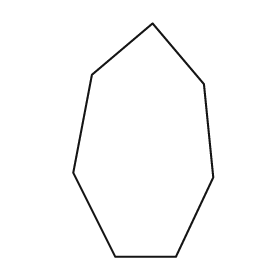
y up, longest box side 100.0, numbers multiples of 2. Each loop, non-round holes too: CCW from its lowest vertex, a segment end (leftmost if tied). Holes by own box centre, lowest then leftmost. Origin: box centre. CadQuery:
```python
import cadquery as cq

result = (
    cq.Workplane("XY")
    .moveTo(-12.0, -50.0)
    .lineTo(14.0, -50.0)
    .lineTo(30.0, -16.0)
    .lineTo(26.0, 24.0)
    .lineTo(4.0, 50.0)
    .lineTo(-22.0, 28.0)
    .lineTo(-30.0, -14.0)
    .close()
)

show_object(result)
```